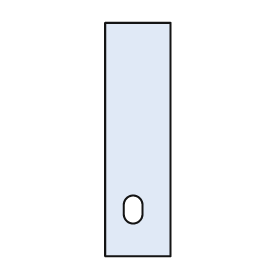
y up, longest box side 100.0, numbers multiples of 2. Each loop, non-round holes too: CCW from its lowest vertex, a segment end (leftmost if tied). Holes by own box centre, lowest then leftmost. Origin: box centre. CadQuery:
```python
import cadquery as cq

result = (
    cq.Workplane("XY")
    .moveTo(-14.0, -50.0)
    .lineTo(14.0, -50.0)
    .lineTo(14.0, 50.0)
    .lineTo(-14.0, 50.0)
    .close()
    .moveTo(-6.0, -32.0)
    .threePointArc((-2.0, -36.0), (2.0, -32.0))
    .lineTo(2.0, -28.0)
    .threePointArc((-2.0, -24.0), (-6.0, -28.0))
    .close()
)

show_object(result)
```